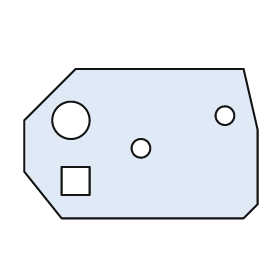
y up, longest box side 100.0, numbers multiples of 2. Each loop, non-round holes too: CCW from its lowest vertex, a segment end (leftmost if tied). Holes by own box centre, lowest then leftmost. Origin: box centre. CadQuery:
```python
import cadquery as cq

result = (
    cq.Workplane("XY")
    .moveTo(-34.0, -32.0)
    .lineTo(44.0, -32.0)
    .lineTo(50.0, -26.0)
    .lineTo(50.0, 6.0)
    .lineTo(44.0, 32.0)
    .lineTo(-28.0, 32.0)
    .lineTo(-50.0, 10.0)
    .lineTo(-50.0, -12.0)
    .close()
    .moveTo(-34.0, -22.0)
    .lineTo(-22.0, -22.0)
    .lineTo(-22.0, -10.0)
    .lineTo(-34.0, -10.0)
    .close()
    .moveTo(0.0, -2.0)
    .circle(4.0)
    .moveTo(-30.0, 10.0)
    .circle(8.0)
    .moveTo(36.0, 12.0)
    .circle(4.0)
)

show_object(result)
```